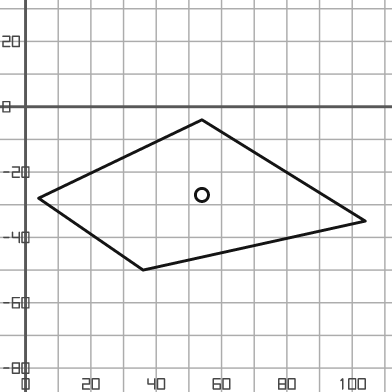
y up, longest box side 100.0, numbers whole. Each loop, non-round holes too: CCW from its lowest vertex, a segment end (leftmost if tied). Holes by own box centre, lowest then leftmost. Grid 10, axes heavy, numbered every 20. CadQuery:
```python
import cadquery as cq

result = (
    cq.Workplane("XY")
    .moveTo(36.0, -50.0)
    .lineTo(104.0, -35.0)
    .lineTo(54.0, -4.0)
    .lineTo(4.0, -28.0)
    .close()
    .moveTo(54.0, -27.0)
    .circle(2.0)
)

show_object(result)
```